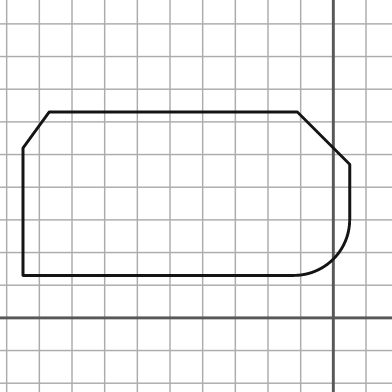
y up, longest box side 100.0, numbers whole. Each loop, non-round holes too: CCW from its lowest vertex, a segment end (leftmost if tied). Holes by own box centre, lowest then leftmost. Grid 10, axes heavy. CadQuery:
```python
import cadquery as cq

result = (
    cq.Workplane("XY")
    .moveTo(-95.0, 13.0)
    .lineTo(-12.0, 13.0)
    .threePointArc((0.0, 18.0), (5.0, 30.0))
    .lineTo(5.0, 47.0)
    .lineTo(-11.0, 63.0)
    .lineTo(-87.0, 63.0)
    .lineTo(-95.0, 52.0)
    .close()
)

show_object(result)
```